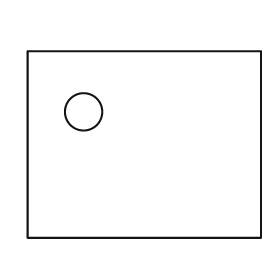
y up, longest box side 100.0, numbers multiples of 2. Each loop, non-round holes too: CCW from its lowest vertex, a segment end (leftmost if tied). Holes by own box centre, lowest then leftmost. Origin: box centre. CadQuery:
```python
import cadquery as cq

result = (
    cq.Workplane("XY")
    .moveTo(-50.0, -40.0)
    .lineTo(50.0, -40.0)
    .lineTo(50.0, 40.0)
    .lineTo(-50.0, 40.0)
    .close()
    .moveTo(-26.0, 14.0)
    .circle(8.0)
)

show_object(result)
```